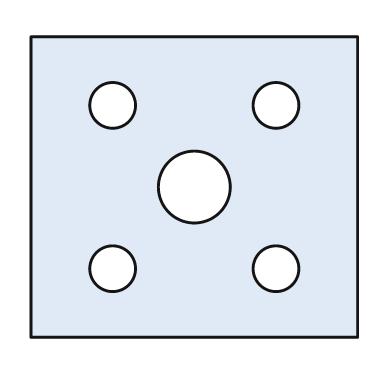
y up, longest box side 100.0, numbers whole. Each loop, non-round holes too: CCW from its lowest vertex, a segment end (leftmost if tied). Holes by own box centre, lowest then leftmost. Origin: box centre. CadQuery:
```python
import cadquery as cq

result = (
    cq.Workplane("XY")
    .moveTo(-50.0, -46.0)
    .lineTo(50.0, -46.0)
    .lineTo(50.0, 46.0)
    .lineTo(-50.0, 46.0)
    .close()
    .moveTo(-25.0, -25.0)
    .circle(7.0)
    .moveTo(25.0, -25.0)
    .circle(7.0)
    .moveTo(0.0, 0.0)
    .circle(11.0)
    .moveTo(-25.0, 25.0)
    .circle(7.0)
    .moveTo(25.0, 25.0)
    .circle(7.0)
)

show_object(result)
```